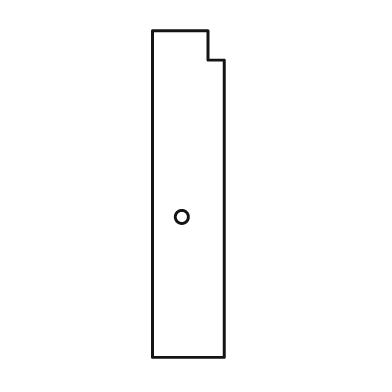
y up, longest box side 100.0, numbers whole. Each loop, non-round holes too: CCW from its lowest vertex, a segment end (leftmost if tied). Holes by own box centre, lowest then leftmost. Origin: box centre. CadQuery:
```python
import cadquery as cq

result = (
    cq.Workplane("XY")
    .moveTo(-11.0, -50.0)
    .lineTo(11.0, -50.0)
    .lineTo(11.0, 41.0)
    .lineTo(6.0, 41.0)
    .lineTo(6.0, 50.0)
    .lineTo(-11.0, 50.0)
    .close()
    .moveTo(-2.0, -7.0)
    .circle(2.0)
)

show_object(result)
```